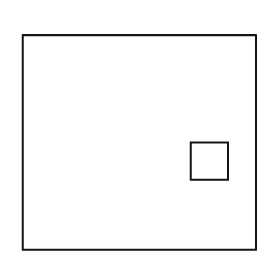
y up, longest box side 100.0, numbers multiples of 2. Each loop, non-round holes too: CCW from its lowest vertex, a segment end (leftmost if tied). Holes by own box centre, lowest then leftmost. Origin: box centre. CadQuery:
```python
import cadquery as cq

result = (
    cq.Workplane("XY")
    .moveTo(-50.0, -46.0)
    .lineTo(50.0, -46.0)
    .lineTo(50.0, 46.0)
    .lineTo(-50.0, 46.0)
    .close()
    .moveTo(22.0, -16.0)
    .lineTo(38.0, -16.0)
    .lineTo(38.0, 0.0)
    .lineTo(22.0, 0.0)
    .close()
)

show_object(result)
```